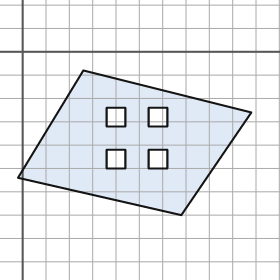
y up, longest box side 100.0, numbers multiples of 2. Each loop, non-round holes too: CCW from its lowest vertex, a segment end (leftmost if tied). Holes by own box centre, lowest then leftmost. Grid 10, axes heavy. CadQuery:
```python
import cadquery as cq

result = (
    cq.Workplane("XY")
    .moveTo(68.0, -70.0)
    .lineTo(98.0, -26.0)
    .lineTo(26.0, -8.0)
    .lineTo(-2.0, -54.0)
    .close()
    .moveTo(36.0, -50.0)
    .lineTo(44.0, -50.0)
    .lineTo(44.0, -42.0)
    .lineTo(36.0, -42.0)
    .close()
    .moveTo(54.0, -50.0)
    .lineTo(62.0, -50.0)
    .lineTo(62.0, -42.0)
    .lineTo(54.0, -42.0)
    .close()
    .moveTo(36.0, -32.0)
    .lineTo(44.0, -32.0)
    .lineTo(44.0, -24.0)
    .lineTo(36.0, -24.0)
    .close()
    .moveTo(54.0, -32.0)
    .lineTo(62.0, -32.0)
    .lineTo(62.0, -24.0)
    .lineTo(54.0, -24.0)
    .close()
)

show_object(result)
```